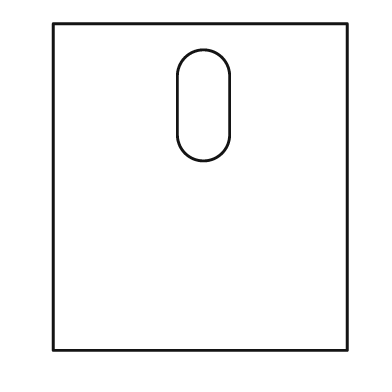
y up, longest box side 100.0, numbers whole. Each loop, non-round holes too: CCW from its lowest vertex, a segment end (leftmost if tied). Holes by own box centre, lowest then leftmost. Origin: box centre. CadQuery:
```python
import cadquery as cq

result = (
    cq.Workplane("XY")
    .moveTo(-45.0, -50.0)
    .lineTo(45.0, -50.0)
    .lineTo(45.0, 50.0)
    .lineTo(-45.0, 50.0)
    .close()
    .moveTo(-7.0, 16.0)
    .threePointArc((1.0, 8.0), (9.0, 16.0))
    .lineTo(9.0, 34.0)
    .threePointArc((1.0, 42.0), (-7.0, 34.0))
    .close()
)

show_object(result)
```